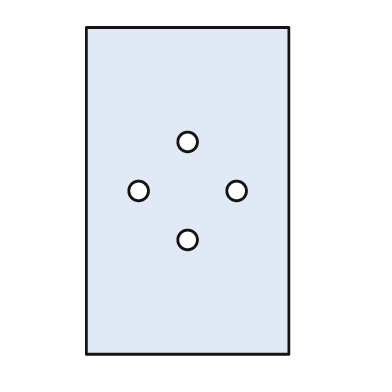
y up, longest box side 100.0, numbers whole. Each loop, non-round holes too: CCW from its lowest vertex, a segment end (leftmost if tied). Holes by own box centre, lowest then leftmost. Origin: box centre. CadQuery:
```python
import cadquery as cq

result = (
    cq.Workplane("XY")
    .moveTo(-31.0, -50.0)
    .lineTo(31.0, -50.0)
    .lineTo(31.0, 50.0)
    .lineTo(-31.0, 50.0)
    .close()
    .moveTo(0.0, -15.0)
    .circle(3.0)
    .moveTo(-15.0, 0.0)
    .circle(3.0)
    .moveTo(15.0, 0.0)
    .circle(3.0)
    .moveTo(0.0, 15.0)
    .circle(3.0)
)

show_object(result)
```